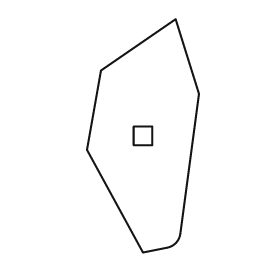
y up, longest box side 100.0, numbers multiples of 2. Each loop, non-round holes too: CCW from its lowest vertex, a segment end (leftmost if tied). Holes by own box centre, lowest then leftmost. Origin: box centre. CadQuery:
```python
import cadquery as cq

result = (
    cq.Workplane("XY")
    .moveTo(0.0, -50.0)
    .lineTo(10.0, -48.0)
    .threePointArc((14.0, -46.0), (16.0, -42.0))
    .lineTo(24.0, 18.0)
    .lineTo(14.0, 50.0)
    .lineTo(-18.0, 28.0)
    .lineTo(-24.0, -6.0)
    .close()
    .moveTo(-4.0, -4.0)
    .lineTo(4.0, -4.0)
    .lineTo(4.0, 4.0)
    .lineTo(-4.0, 4.0)
    .close()
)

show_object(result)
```